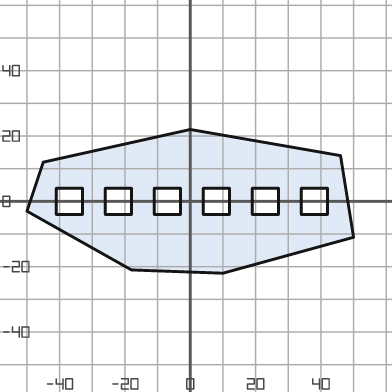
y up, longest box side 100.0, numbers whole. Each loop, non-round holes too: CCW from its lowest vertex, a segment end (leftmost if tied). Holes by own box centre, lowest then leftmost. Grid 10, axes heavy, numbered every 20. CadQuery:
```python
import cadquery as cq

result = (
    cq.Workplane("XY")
    .moveTo(10.0, -22.0)
    .lineTo(50.0, -11.0)
    .lineTo(46.0, 14.0)
    .lineTo(0.0, 22.0)
    .lineTo(-45.0, 12.0)
    .lineTo(-50.0, -3.0)
    .lineTo(-18.0, -21.0)
    .close()
    .moveTo(-41.0, -4.0)
    .lineTo(-33.0, -4.0)
    .lineTo(-33.0, 4.0)
    .lineTo(-41.0, 4.0)
    .close()
    .moveTo(-26.0, -4.0)
    .lineTo(-18.0, -4.0)
    .lineTo(-18.0, 4.0)
    .lineTo(-26.0, 4.0)
    .close()
    .moveTo(-11.0, -4.0)
    .lineTo(-3.0, -4.0)
    .lineTo(-3.0, 4.0)
    .lineTo(-11.0, 4.0)
    .close()
    .moveTo(4.0, -4.0)
    .lineTo(12.0, -4.0)
    .lineTo(12.0, 4.0)
    .lineTo(4.0, 4.0)
    .close()
    .moveTo(19.0, -4.0)
    .lineTo(27.0, -4.0)
    .lineTo(27.0, 4.0)
    .lineTo(19.0, 4.0)
    .close()
    .moveTo(34.0, -4.0)
    .lineTo(42.0, -4.0)
    .lineTo(42.0, 4.0)
    .lineTo(34.0, 4.0)
    .close()
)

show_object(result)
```